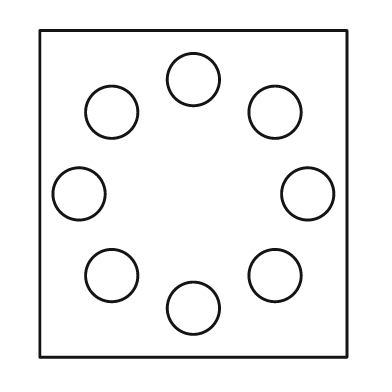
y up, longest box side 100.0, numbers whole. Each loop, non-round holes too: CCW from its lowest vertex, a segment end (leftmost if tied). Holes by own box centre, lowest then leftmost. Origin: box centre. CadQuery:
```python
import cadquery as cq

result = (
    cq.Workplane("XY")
    .moveTo(-47.0, -50.0)
    .lineTo(47.0, -50.0)
    .lineTo(47.0, 50.0)
    .lineTo(-47.0, 50.0)
    .close()
    .moveTo(0.0, -35.0)
    .circle(8.0)
    .moveTo(-25.0, -25.0)
    .circle(8.0)
    .moveTo(25.0, -25.0)
    .circle(8.0)
    .moveTo(-35.0, 0.0)
    .circle(8.0)
    .moveTo(35.0, 0.0)
    .circle(8.0)
    .moveTo(-25.0, 25.0)
    .circle(8.0)
    .moveTo(25.0, 25.0)
    .circle(8.0)
    .moveTo(0.0, 35.0)
    .circle(8.0)
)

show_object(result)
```